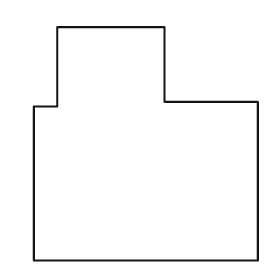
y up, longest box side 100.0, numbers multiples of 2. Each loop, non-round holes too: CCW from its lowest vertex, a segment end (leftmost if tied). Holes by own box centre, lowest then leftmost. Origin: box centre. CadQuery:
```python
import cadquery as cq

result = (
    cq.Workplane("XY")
    .moveTo(-48.0, -50.0)
    .lineTo(48.0, -50.0)
    .lineTo(48.0, 18.0)
    .lineTo(8.0, 18.0)
    .lineTo(8.0, 50.0)
    .lineTo(-38.0, 50.0)
    .lineTo(-38.0, 16.0)
    .lineTo(-48.0, 16.0)
    .close()
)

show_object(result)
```